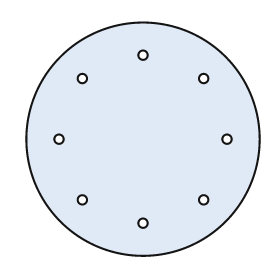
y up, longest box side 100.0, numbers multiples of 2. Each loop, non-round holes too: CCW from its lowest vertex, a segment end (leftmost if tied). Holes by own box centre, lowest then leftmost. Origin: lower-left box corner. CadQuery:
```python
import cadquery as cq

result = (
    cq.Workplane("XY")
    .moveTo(50.0, 50.0)
    .circle(50.0)
    .moveTo(50.0, 14.0)
    .circle(2.0)
    .moveTo(24.0, 24.0)
    .circle(2.0)
    .moveTo(76.0, 24.0)
    .circle(2.0)
    .moveTo(14.0, 50.0)
    .circle(2.0)
    .moveTo(86.0, 50.0)
    .circle(2.0)
    .moveTo(24.0, 76.0)
    .circle(2.0)
    .moveTo(76.0, 76.0)
    .circle(2.0)
    .moveTo(50.0, 86.0)
    .circle(2.0)
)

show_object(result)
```